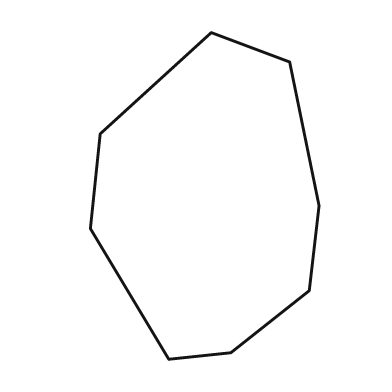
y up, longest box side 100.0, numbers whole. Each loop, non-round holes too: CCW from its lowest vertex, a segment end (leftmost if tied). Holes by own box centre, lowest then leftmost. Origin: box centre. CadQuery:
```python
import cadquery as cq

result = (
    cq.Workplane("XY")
    .moveTo(-11.0, -50.0)
    .lineTo(8.0, -48.0)
    .lineTo(32.0, -29.0)
    .lineTo(35.0, -3.0)
    .lineTo(26.0, 41.0)
    .lineTo(2.0, 50.0)
    .lineTo(-32.0, 19.0)
    .lineTo(-35.0, -10.0)
    .close()
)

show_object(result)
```